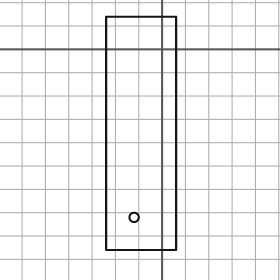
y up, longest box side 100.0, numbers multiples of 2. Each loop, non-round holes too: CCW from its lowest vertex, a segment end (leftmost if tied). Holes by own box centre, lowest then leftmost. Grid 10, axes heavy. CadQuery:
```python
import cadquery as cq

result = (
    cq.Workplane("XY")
    .moveTo(-24.0, -86.0)
    .lineTo(6.0, -86.0)
    .lineTo(6.0, 14.0)
    .lineTo(-24.0, 14.0)
    .close()
    .moveTo(-12.0, -72.0)
    .circle(2.0)
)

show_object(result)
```